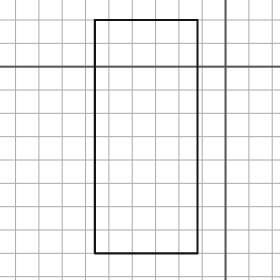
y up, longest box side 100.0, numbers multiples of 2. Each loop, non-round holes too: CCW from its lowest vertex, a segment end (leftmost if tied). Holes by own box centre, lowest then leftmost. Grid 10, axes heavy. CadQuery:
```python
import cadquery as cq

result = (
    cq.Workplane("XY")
    .moveTo(-56.0, -80.0)
    .lineTo(-12.0, -80.0)
    .lineTo(-12.0, 20.0)
    .lineTo(-56.0, 20.0)
    .close()
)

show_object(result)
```